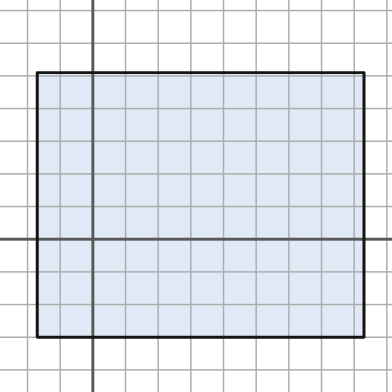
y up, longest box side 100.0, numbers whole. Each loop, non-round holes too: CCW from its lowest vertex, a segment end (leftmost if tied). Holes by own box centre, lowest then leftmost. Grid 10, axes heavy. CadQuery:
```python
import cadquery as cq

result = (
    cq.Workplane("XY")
    .moveTo(-17.0, -30.0)
    .lineTo(83.0, -30.0)
    .lineTo(83.0, 51.0)
    .lineTo(-17.0, 51.0)
    .close()
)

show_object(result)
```